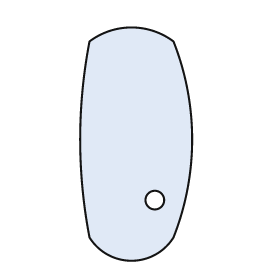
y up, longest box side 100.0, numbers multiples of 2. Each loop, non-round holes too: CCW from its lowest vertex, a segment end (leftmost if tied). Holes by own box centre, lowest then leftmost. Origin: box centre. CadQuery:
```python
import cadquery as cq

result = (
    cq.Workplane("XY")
    .moveTo(-20.0, -40.0)
    .threePointArc((-2.0, -50.0), (16.0, -40.0))
    .threePointArc((24.0, 2.0), (16.0, 44.0))
    .threePointArc((-2.0, 50.0), (-20.0, 44.0))
    .threePointArc((-24.0, 2.0), (-20.0, -40.0))
    .close()
    .moveTo(8.0, -24.0)
    .circle(4.0)
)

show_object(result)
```